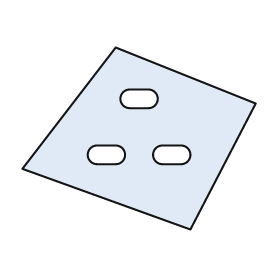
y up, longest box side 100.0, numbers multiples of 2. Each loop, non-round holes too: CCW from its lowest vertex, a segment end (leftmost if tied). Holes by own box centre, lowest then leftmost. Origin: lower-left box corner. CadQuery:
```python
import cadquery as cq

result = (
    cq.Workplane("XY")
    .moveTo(72.0, 0.0)
    .lineTo(100.0, 54.0)
    .lineTo(40.0, 78.0)
    .lineTo(0.0, 26.0)
    .close()
    .moveTo(32.0, 28.0)
    .lineTo(40.0, 28.0)
    .threePointArc((44.0, 32.0), (40.0, 36.0))
    .lineTo(32.0, 36.0)
    .threePointArc((28.0, 32.0), (32.0, 28.0))
    .close()
    .moveTo(60.0, 28.0)
    .lineTo(68.0, 28.0)
    .threePointArc((72.0, 32.0), (68.0, 36.0))
    .lineTo(60.0, 36.0)
    .threePointArc((56.0, 32.0), (60.0, 28.0))
    .close()
    .moveTo(46.0, 52.0)
    .lineTo(54.0, 52.0)
    .threePointArc((58.0, 56.0), (54.0, 60.0))
    .lineTo(46.0, 60.0)
    .threePointArc((42.0, 56.0), (46.0, 52.0))
    .close()
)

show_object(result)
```